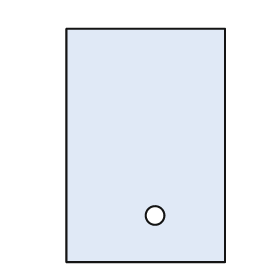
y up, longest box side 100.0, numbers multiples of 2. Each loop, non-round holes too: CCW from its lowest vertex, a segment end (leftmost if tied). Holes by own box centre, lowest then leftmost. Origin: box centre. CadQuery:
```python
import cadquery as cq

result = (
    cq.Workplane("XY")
    .moveTo(-34.0, -50.0)
    .lineTo(34.0, -50.0)
    .lineTo(34.0, 50.0)
    .lineTo(-34.0, 50.0)
    .close()
    .moveTo(4.0, -30.0)
    .circle(4.0)
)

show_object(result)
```